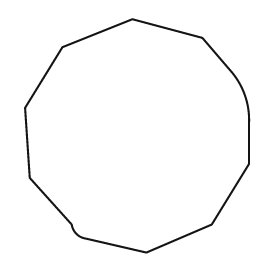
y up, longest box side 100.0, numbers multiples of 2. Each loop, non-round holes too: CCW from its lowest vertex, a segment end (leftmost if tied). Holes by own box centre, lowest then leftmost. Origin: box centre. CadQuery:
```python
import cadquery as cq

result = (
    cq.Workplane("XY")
    .moveTo(4.0, -50.0)
    .lineTo(32.0, -38.0)
    .lineTo(48.0, -12.0)
    .lineTo(48.0, 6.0)
    .threePointArc((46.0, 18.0), (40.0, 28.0))
    .lineTo(28.0, 42.0)
    .lineTo(-2.0, 50.0)
    .lineTo(-32.0, 38.0)
    .lineTo(-48.0, 12.0)
    .lineTo(-46.0, -18.0)
    .lineTo(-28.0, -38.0)
    .threePointArc((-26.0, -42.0), (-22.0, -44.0))
    .close()
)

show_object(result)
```